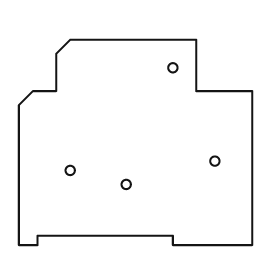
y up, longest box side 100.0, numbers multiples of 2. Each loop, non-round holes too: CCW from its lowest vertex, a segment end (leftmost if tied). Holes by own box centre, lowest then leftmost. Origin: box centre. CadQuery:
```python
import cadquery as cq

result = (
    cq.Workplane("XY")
    .moveTo(-50.0, -44.0)
    .lineTo(-42.0, -44.0)
    .lineTo(-42.0, -40.0)
    .lineTo(16.0, -40.0)
    .lineTo(16.0, -44.0)
    .lineTo(50.0, -44.0)
    .lineTo(50.0, 22.0)
    .lineTo(26.0, 22.0)
    .lineTo(26.0, 44.0)
    .lineTo(-28.0, 44.0)
    .lineTo(-34.0, 38.0)
    .lineTo(-34.0, 22.0)
    .lineTo(-44.0, 22.0)
    .lineTo(-50.0, 16.0)
    .close()
    .moveTo(-4.0, -18.0)
    .circle(2.0)
    .moveTo(-28.0, -12.0)
    .circle(2.0)
    .moveTo(34.0, -8.0)
    .circle(2.0)
    .moveTo(16.0, 32.0)
    .circle(2.0)
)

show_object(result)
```